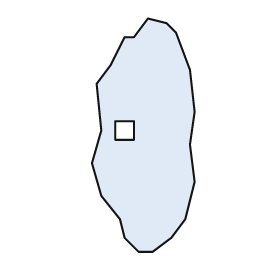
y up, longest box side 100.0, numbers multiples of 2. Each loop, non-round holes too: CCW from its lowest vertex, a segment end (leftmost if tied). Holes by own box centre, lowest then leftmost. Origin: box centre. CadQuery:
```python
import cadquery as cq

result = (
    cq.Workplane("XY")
    .moveTo(-2.0, -50.0)
    .lineTo(4.0, -50.0)
    .lineTo(12.0, -44.0)
    .lineTo(18.0, -36.0)
    .lineTo(22.0, -20.0)
    .lineTo(20.0, -4.0)
    .lineTo(22.0, 10.0)
    .lineTo(20.0, 28.0)
    .lineTo(14.0, 44.0)
    .lineTo(10.0, 48.0)
    .lineTo(2.0, 50.0)
    .lineTo(-4.0, 42.0)
    .lineTo(-8.0, 42.0)
    .lineTo(-14.0, 30.0)
    .lineTo(-20.0, 22.0)
    .lineTo(-18.0, 2.0)
    .lineTo(-22.0, -12.0)
    .lineTo(-18.0, -26.0)
    .lineTo(-10.0, -36.0)
    .lineTo(-8.0, -44.0)
    .close()
    .moveTo(-12.0, -2.0)
    .lineTo(-4.0, -2.0)
    .lineTo(-4.0, 6.0)
    .lineTo(-12.0, 6.0)
    .close()
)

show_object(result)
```